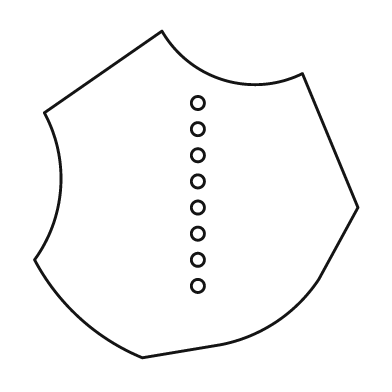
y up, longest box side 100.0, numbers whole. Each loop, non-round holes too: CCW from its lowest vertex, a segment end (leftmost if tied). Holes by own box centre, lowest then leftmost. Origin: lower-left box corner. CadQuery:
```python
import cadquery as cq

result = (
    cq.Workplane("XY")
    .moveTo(33.0, 0.0)
    .lineTo(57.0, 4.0)
    .threePointArc((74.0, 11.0), (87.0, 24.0))
    .lineTo(99.0, 46.0)
    .lineTo(82.0, 87.0)
    .threePointArc((58.0, 85.0), (39.0, 100.0))
    .lineTo(3.0, 75.0)
    .threePointArc((8.0, 52.0), (0.0, 30.0))
    .threePointArc((14.0, 12.0), (33.0, 0.0))
    .close()
    .moveTo(50.0, 22.0)
    .circle(2.0)
    .moveTo(50.0, 30.0)
    .circle(2.0)
    .moveTo(50.0, 38.0)
    .circle(2.0)
    .moveTo(50.0, 46.0)
    .circle(2.0)
    .moveTo(50.0, 54.0)
    .circle(2.0)
    .moveTo(50.0, 62.0)
    .circle(2.0)
    .moveTo(50.0, 70.0)
    .circle(2.0)
    .moveTo(50.0, 78.0)
    .circle(2.0)
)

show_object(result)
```